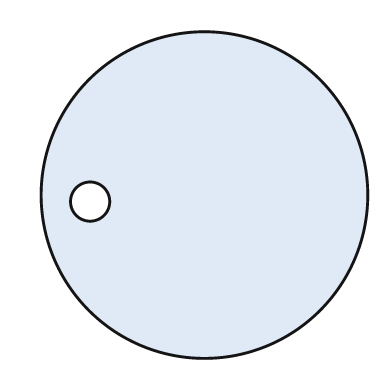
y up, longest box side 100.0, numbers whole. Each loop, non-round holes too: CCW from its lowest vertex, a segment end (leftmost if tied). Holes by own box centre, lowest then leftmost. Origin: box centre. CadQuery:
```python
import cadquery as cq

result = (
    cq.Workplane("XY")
    .moveTo(0.0, 0.0)
    .circle(50.0)
    .moveTo(-35.0, -2.0)
    .circle(6.0)
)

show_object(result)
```